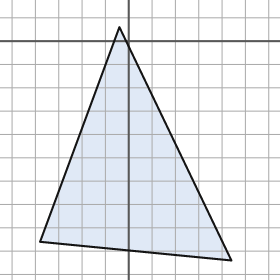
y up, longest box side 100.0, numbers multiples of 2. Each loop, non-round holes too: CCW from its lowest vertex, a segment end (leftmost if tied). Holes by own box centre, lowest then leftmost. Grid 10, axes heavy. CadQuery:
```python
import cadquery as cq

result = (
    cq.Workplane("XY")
    .moveTo(44.0, -94.0)
    .lineTo(-4.0, 6.0)
    .lineTo(-38.0, -86.0)
    .close()
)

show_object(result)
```